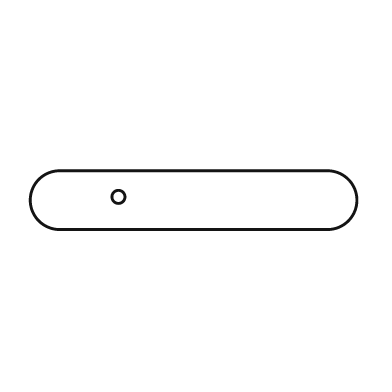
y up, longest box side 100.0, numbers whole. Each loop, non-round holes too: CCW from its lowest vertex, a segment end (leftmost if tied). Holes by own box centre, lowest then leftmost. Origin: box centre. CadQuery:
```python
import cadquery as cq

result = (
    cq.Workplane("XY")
    .moveTo(-41.0, -9.0)
    .lineTo(41.0, -9.0)
    .threePointArc((50.0, 0.0), (41.0, 9.0))
    .lineTo(-41.0, 9.0)
    .threePointArc((-50.0, 0.0), (-41.0, -9.0))
    .close()
    .moveTo(-23.0, 1.0)
    .circle(2.0)
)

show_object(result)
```